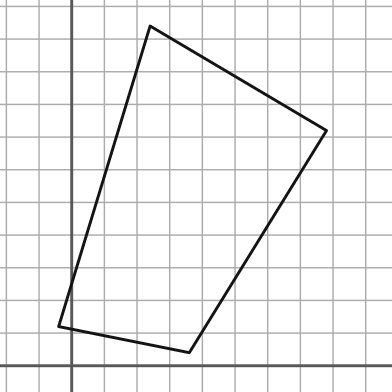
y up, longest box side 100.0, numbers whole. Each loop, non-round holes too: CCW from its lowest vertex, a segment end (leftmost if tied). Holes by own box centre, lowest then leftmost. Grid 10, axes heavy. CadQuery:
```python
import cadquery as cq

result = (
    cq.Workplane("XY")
    .moveTo(36.0, 4.0)
    .lineTo(78.0, 72.0)
    .lineTo(24.0, 104.0)
    .lineTo(-4.0, 12.0)
    .close()
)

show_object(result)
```